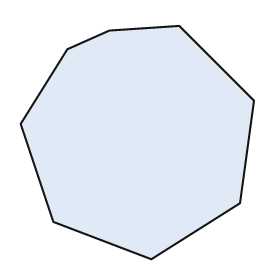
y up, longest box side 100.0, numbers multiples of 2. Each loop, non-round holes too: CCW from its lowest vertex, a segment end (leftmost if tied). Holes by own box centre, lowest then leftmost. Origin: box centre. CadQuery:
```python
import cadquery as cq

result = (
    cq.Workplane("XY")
    .moveTo(6.0, -50.0)
    .lineTo(44.0, -26.0)
    .lineTo(50.0, 18.0)
    .lineTo(18.0, 50.0)
    .lineTo(-12.0, 48.0)
    .lineTo(-30.0, 40.0)
    .lineTo(-50.0, 8.0)
    .lineTo(-36.0, -34.0)
    .close()
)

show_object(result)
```